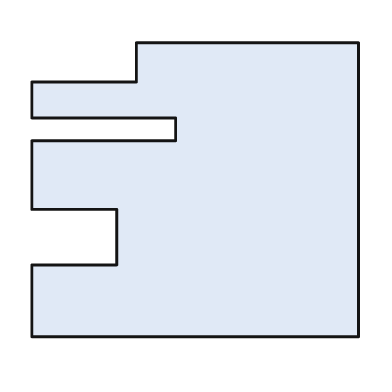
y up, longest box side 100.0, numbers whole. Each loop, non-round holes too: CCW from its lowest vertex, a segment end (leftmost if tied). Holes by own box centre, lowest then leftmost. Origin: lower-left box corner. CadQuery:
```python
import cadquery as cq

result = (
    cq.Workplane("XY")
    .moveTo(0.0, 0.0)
    .lineTo(100.0, 0.0)
    .lineTo(100.0, 90.0)
    .lineTo(32.0, 90.0)
    .lineTo(32.0, 78.0)
    .lineTo(0.0, 78.0)
    .lineTo(0.0, 67.0)
    .lineTo(44.0, 67.0)
    .lineTo(44.0, 60.0)
    .lineTo(0.0, 60.0)
    .lineTo(0.0, 39.0)
    .lineTo(26.0, 39.0)
    .lineTo(26.0, 22.0)
    .lineTo(0.0, 22.0)
    .close()
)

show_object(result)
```